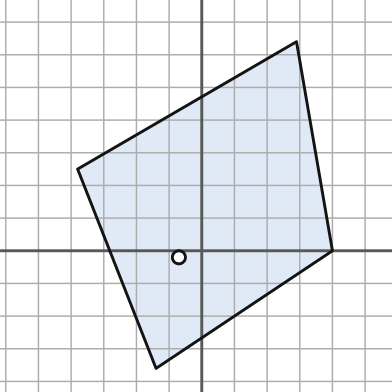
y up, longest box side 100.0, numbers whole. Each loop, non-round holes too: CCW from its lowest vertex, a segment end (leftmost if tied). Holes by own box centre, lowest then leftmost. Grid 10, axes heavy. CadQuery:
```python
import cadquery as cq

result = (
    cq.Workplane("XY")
    .moveTo(-14.0, -36.0)
    .lineTo(40.0, 0.0)
    .lineTo(29.0, 64.0)
    .lineTo(-38.0, 25.0)
    .close()
    .moveTo(-7.0, -2.0)
    .circle(2.0)
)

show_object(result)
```